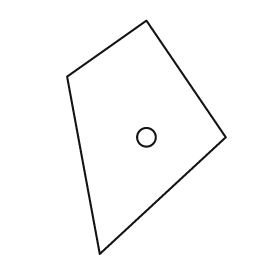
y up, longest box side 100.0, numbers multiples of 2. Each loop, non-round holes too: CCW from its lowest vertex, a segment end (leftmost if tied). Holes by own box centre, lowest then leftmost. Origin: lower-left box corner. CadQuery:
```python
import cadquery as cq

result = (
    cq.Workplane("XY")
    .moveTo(14.0, 0.0)
    .lineTo(68.0, 50.0)
    .lineTo(34.0, 100.0)
    .lineTo(0.0, 76.0)
    .close()
    .moveTo(34.0, 50.0)
    .circle(4.0)
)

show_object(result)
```